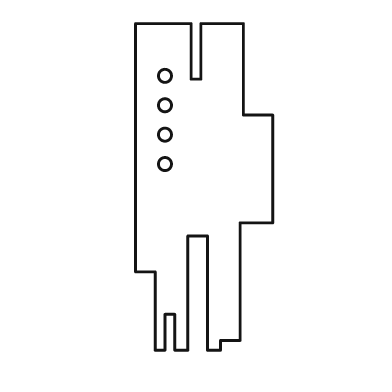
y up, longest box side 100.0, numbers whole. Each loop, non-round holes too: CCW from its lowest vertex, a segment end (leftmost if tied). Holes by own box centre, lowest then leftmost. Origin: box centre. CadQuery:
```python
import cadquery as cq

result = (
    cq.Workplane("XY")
    .moveTo(-15.0, -50.0)
    .lineTo(-12.0, -50.0)
    .lineTo(-12.0, -39.0)
    .lineTo(-9.0, -39.0)
    .lineTo(-9.0, -50.0)
    .lineTo(-5.0, -50.0)
    .lineTo(-5.0, -15.0)
    .lineTo(1.0, -15.0)
    .lineTo(1.0, -50.0)
    .lineTo(5.0, -50.0)
    .lineTo(5.0, -47.0)
    .lineTo(11.0, -47.0)
    .lineTo(11.0, -11.0)
    .lineTo(21.0, -11.0)
    .lineTo(21.0, 22.0)
    .lineTo(12.0, 22.0)
    .lineTo(12.0, 50.0)
    .lineTo(-1.0, 50.0)
    .lineTo(-1.0, 33.0)
    .lineTo(-4.0, 33.0)
    .lineTo(-4.0, 50.0)
    .lineTo(-21.0, 50.0)
    .lineTo(-21.0, -26.0)
    .lineTo(-15.0, -26.0)
    .close()
    .moveTo(-12.0, 7.0)
    .circle(2.0)
    .moveTo(-12.0, 16.0)
    .circle(2.0)
    .moveTo(-12.0, 25.0)
    .circle(2.0)
    .moveTo(-12.0, 34.0)
    .circle(2.0)
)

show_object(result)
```